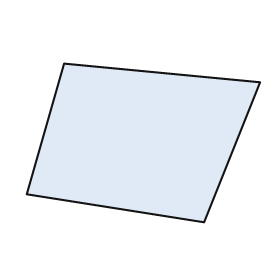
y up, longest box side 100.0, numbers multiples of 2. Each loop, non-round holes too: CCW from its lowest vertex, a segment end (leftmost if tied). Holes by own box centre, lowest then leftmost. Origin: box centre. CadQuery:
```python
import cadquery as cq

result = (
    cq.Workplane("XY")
    .moveTo(26.0, -34.0)
    .lineTo(50.0, 26.0)
    .lineTo(-34.0, 34.0)
    .lineTo(-50.0, -22.0)
    .close()
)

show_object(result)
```